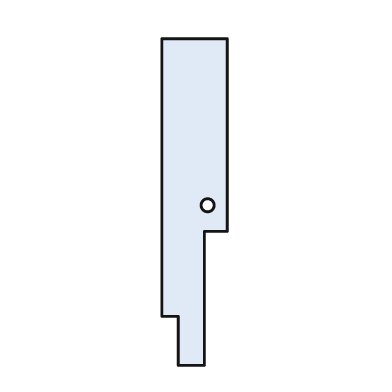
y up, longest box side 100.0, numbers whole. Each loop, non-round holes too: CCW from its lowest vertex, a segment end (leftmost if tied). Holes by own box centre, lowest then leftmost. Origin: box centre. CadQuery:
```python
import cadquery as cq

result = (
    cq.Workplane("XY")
    .moveTo(-5.0, -50.0)
    .lineTo(3.0, -50.0)
    .lineTo(3.0, -9.0)
    .lineTo(10.0, -9.0)
    .lineTo(10.0, 50.0)
    .lineTo(-10.0, 50.0)
    .lineTo(-10.0, -35.0)
    .lineTo(-5.0, -35.0)
    .close()
    .moveTo(4.0, -1.0)
    .circle(2.0)
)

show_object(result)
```